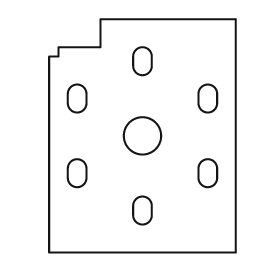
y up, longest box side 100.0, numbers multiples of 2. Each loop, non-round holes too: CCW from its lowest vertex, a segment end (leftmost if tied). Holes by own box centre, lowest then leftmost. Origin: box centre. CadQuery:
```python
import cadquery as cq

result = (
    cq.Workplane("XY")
    .moveTo(-40.0, -50.0)
    .lineTo(40.0, -50.0)
    .lineTo(40.0, 50.0)
    .lineTo(-18.0, 50.0)
    .lineTo(-18.0, 38.0)
    .lineTo(-36.0, 38.0)
    .lineTo(-36.0, 34.0)
    .lineTo(-40.0, 34.0)
    .close()
    .moveTo(-4.0, -34.0)
    .threePointArc((0.0, -38.0), (4.0, -34.0))
    .lineTo(4.0, -30.0)
    .threePointArc((0.0, -26.0), (-4.0, -30.0))
    .close()
    .moveTo(-32.0, -18.0)
    .threePointArc((-28.0, -22.0), (-24.0, -18.0))
    .lineTo(-24.0, -14.0)
    .threePointArc((-28.0, -10.0), (-32.0, -14.0))
    .close()
    .moveTo(24.0, -18.0)
    .threePointArc((28.0, -22.0), (32.0, -18.0))
    .lineTo(32.0, -14.0)
    .threePointArc((28.0, -10.0), (24.0, -14.0))
    .close()
    .moveTo(0.0, 0.0)
    .circle(8.0)
    .moveTo(-32.0, 14.0)
    .threePointArc((-28.0, 10.0), (-24.0, 14.0))
    .lineTo(-24.0, 18.0)
    .threePointArc((-28.0, 22.0), (-32.0, 18.0))
    .close()
    .moveTo(24.0, 14.0)
    .threePointArc((28.0, 10.0), (32.0, 14.0))
    .lineTo(32.0, 18.0)
    .threePointArc((28.0, 22.0), (24.0, 18.0))
    .close()
    .moveTo(-4.0, 30.0)
    .threePointArc((0.0, 26.0), (4.0, 30.0))
    .lineTo(4.0, 34.0)
    .threePointArc((0.0, 38.0), (-4.0, 34.0))
    .close()
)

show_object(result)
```